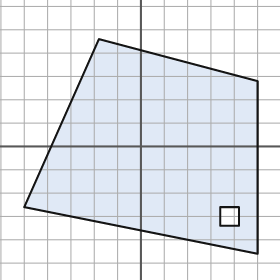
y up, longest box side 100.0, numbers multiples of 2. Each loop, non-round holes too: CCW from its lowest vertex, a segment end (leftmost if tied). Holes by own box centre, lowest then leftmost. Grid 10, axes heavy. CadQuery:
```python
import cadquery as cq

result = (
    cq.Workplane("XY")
    .moveTo(50.0, -46.0)
    .lineTo(50.0, 28.0)
    .lineTo(-18.0, 46.0)
    .lineTo(-50.0, -26.0)
    .close()
    .moveTo(34.0, -34.0)
    .lineTo(42.0, -34.0)
    .lineTo(42.0, -26.0)
    .lineTo(34.0, -26.0)
    .close()
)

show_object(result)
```